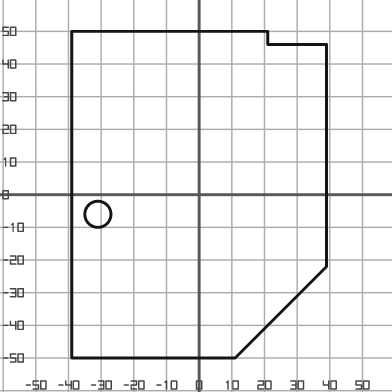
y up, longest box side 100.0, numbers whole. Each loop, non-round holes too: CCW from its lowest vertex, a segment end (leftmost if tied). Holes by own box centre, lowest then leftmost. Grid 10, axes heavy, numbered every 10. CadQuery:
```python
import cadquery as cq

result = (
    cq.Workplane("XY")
    .moveTo(-39.0, -50.0)
    .lineTo(11.0, -50.0)
    .lineTo(39.0, -22.0)
    .lineTo(39.0, 46.0)
    .lineTo(21.0, 46.0)
    .lineTo(21.0, 50.0)
    .lineTo(-39.0, 50.0)
    .close()
    .moveTo(-31.0, -6.0)
    .circle(4.0)
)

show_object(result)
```